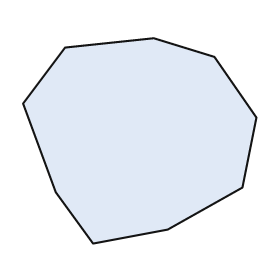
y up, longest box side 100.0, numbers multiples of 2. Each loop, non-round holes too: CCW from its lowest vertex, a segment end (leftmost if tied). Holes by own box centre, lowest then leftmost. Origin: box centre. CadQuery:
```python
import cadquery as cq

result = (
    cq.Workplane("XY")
    .moveTo(-20.0, -44.0)
    .lineTo(12.0, -38.0)
    .lineTo(44.0, -20.0)
    .lineTo(50.0, 10.0)
    .lineTo(32.0, 36.0)
    .lineTo(6.0, 44.0)
    .lineTo(-32.0, 40.0)
    .lineTo(-50.0, 16.0)
    .lineTo(-36.0, -22.0)
    .close()
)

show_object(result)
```